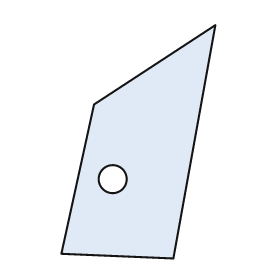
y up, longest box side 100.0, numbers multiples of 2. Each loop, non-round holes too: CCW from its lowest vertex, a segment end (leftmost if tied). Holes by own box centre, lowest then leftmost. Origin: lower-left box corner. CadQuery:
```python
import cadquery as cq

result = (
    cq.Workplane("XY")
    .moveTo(48.0, 0.0)
    .lineTo(66.0, 100.0)
    .lineTo(14.0, 66.0)
    .lineTo(0.0, 2.0)
    .close()
    .moveTo(22.0, 34.0)
    .circle(6.0)
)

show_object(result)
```